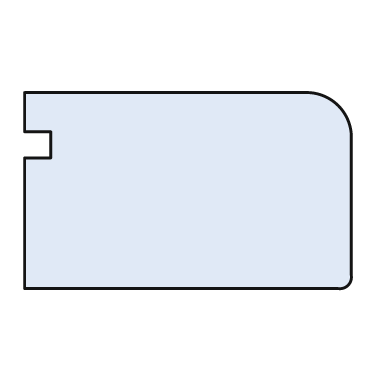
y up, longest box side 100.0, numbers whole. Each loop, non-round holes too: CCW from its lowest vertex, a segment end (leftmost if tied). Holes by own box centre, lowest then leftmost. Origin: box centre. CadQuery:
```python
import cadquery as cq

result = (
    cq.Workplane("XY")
    .moveTo(-50.0, -30.0)
    .lineTo(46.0, -30.0)
    .threePointArc((49.0, -29.0), (50.0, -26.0))
    .lineTo(50.0, 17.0)
    .threePointArc((46.0, 26.0), (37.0, 30.0))
    .lineTo(-50.0, 30.0)
    .lineTo(-50.0, 18.0)
    .lineTo(-42.0, 18.0)
    .lineTo(-42.0, 10.0)
    .lineTo(-50.0, 10.0)
    .close()
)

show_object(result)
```